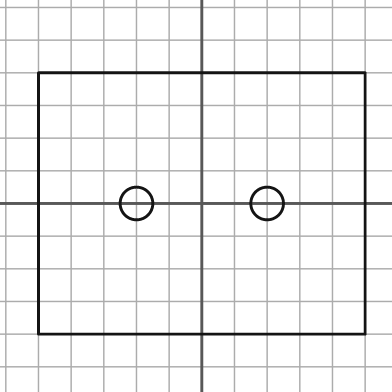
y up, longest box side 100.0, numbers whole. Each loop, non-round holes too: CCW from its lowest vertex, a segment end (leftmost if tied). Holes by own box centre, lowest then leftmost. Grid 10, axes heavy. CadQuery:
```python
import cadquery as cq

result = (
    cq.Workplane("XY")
    .moveTo(-50.0, -40.0)
    .lineTo(50.0, -40.0)
    .lineTo(50.0, 40.0)
    .lineTo(-50.0, 40.0)
    .close()
    .moveTo(-20.0, 0.0)
    .circle(5.0)
    .moveTo(20.0, 0.0)
    .circle(5.0)
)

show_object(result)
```